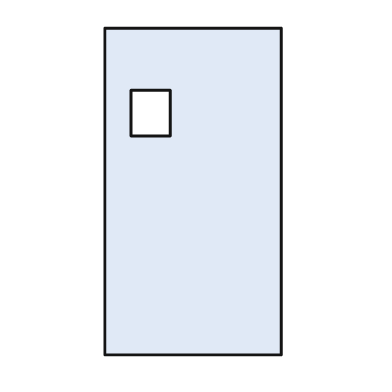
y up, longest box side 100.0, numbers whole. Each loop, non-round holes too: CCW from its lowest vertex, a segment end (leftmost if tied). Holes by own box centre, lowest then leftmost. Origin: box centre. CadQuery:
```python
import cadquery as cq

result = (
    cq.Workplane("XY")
    .moveTo(-27.0, -50.0)
    .lineTo(27.0, -50.0)
    .lineTo(27.0, 50.0)
    .lineTo(-27.0, 50.0)
    .close()
    .moveTo(-19.0, 17.0)
    .lineTo(-7.0, 17.0)
    .lineTo(-7.0, 31.0)
    .lineTo(-19.0, 31.0)
    .close()
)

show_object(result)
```